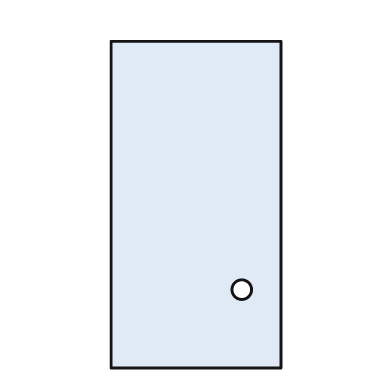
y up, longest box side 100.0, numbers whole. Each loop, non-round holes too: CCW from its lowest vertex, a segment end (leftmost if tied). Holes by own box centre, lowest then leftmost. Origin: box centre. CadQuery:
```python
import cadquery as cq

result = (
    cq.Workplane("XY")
    .moveTo(-26.0, -50.0)
    .lineTo(26.0, -50.0)
    .lineTo(26.0, 50.0)
    .lineTo(-26.0, 50.0)
    .close()
    .moveTo(14.0, -26.0)
    .circle(3.0)
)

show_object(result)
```